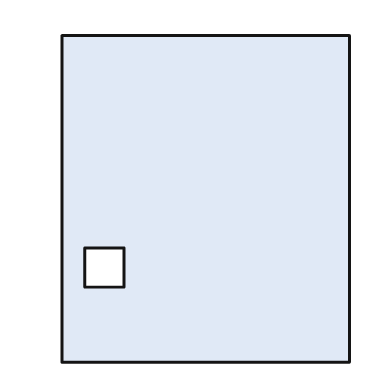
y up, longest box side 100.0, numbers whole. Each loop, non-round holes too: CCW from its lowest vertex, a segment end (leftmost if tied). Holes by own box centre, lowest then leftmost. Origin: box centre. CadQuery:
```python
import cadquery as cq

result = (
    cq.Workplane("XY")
    .moveTo(-44.0, -50.0)
    .lineTo(44.0, -50.0)
    .lineTo(44.0, 50.0)
    .lineTo(-44.0, 50.0)
    .close()
    .moveTo(-37.0, -27.0)
    .lineTo(-25.0, -27.0)
    .lineTo(-25.0, -15.0)
    .lineTo(-37.0, -15.0)
    .close()
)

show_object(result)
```